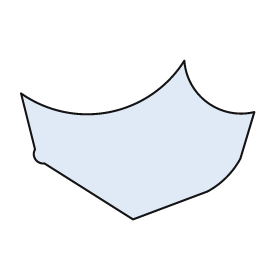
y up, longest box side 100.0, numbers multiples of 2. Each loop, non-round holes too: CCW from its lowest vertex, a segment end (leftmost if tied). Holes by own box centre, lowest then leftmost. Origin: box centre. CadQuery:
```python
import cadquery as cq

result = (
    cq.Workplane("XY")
    .moveTo(-2.0, -34.0)
    .lineTo(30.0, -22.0)
    .threePointArc((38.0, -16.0), (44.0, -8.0))
    .lineTo(50.0, 12.0)
    .threePointArc((30.0, 16.0), (20.0, 34.0))
    .threePointArc((-12.0, 12.0), (-50.0, 20.0))
    .lineTo(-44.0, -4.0)
    .threePointArc((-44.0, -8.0), (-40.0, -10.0))
    .close()
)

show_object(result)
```